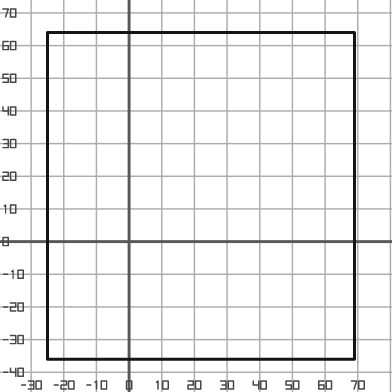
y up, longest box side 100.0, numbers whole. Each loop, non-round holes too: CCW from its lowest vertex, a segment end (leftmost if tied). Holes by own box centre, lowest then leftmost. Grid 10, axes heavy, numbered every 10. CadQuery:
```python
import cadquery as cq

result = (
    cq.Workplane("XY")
    .moveTo(-25.0, -36.0)
    .lineTo(69.0, -36.0)
    .lineTo(69.0, 64.0)
    .lineTo(-25.0, 64.0)
    .close()
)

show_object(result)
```